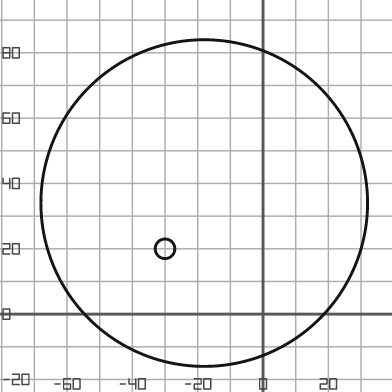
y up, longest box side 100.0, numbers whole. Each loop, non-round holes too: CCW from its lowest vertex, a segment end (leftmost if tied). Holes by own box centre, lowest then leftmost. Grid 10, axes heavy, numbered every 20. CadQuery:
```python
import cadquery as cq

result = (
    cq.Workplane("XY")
    .moveTo(-18.0, 34.0)
    .circle(50.0)
    .moveTo(-30.0, 20.0)
    .circle(3.0)
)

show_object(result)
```